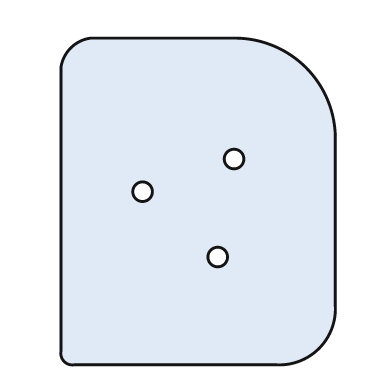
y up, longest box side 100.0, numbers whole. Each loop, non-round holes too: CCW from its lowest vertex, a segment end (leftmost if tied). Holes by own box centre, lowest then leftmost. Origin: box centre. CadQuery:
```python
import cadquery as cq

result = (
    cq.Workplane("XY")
    .moveTo(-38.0, -50.0)
    .lineTo(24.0, -50.0)
    .threePointArc((37.0, -45.0), (42.0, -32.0))
    .lineTo(42.0, 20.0)
    .threePointArc((33.0, 41.0), (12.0, 50.0))
    .lineTo(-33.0, 50.0)
    .threePointArc((-39.0, 47.0), (-42.0, 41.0))
    .lineTo(-42.0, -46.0)
    .threePointArc((-41.0, -49.0), (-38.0, -50.0))
    .close()
    .moveTo(6.0, -17.0)
    .circle(3.0)
    .moveTo(-17.0, 3.0)
    .circle(3.0)
    .moveTo(11.0, 13.0)
    .circle(3.0)
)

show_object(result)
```